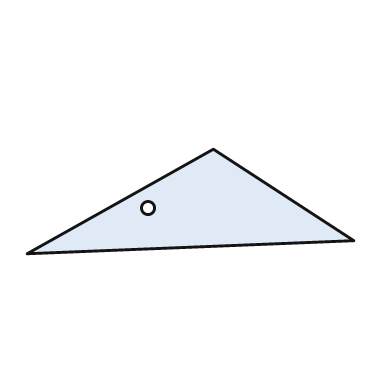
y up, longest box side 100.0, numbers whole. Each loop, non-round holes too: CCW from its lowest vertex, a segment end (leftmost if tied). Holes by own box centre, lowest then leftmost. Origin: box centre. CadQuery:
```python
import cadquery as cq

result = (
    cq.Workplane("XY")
    .moveTo(-50.0, -16.0)
    .lineTo(50.0, -12.0)
    .lineTo(7.0, 16.0)
    .close()
    .moveTo(-13.0, -2.0)
    .circle(2.0)
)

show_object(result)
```